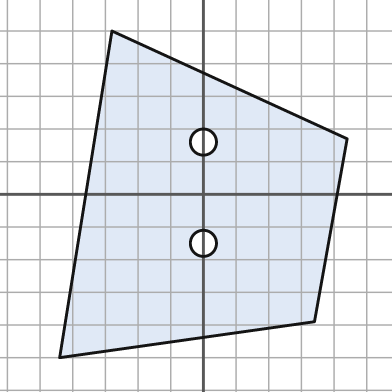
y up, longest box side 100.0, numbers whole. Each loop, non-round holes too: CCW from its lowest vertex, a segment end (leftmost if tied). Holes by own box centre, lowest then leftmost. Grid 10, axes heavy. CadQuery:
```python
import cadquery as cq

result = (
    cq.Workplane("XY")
    .moveTo(-44.0, -50.0)
    .lineTo(34.0, -39.0)
    .lineTo(44.0, 17.0)
    .lineTo(-28.0, 50.0)
    .close()
    .moveTo(0.0, -15.0)
    .circle(4.0)
    .moveTo(0.0, 16.0)
    .circle(4.0)
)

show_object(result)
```